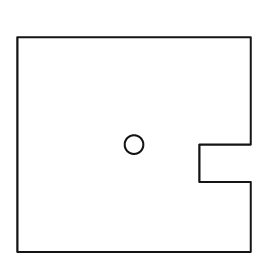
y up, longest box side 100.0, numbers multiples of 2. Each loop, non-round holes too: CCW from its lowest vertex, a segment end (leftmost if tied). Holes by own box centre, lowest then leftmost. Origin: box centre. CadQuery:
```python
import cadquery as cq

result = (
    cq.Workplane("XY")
    .moveTo(-50.0, -46.0)
    .lineTo(50.0, -46.0)
    .lineTo(50.0, -16.0)
    .lineTo(28.0, -16.0)
    .lineTo(28.0, 0.0)
    .lineTo(50.0, 0.0)
    .lineTo(50.0, 46.0)
    .lineTo(-50.0, 46.0)
    .close()
    .moveTo(0.0, 0.0)
    .circle(4.0)
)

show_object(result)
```